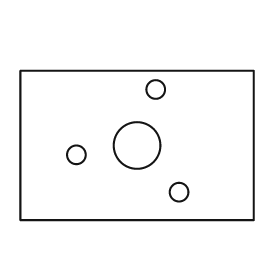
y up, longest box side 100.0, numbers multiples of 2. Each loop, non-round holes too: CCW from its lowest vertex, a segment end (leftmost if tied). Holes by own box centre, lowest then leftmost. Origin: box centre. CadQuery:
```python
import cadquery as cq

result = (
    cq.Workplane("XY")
    .moveTo(-50.0, -32.0)
    .lineTo(50.0, -32.0)
    .lineTo(50.0, 32.0)
    .lineTo(-50.0, 32.0)
    .close()
    .moveTo(18.0, -20.0)
    .circle(4.0)
    .moveTo(-26.0, -4.0)
    .circle(4.0)
    .moveTo(0.0, 0.0)
    .circle(10.0)
    .moveTo(8.0, 24.0)
    .circle(4.0)
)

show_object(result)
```